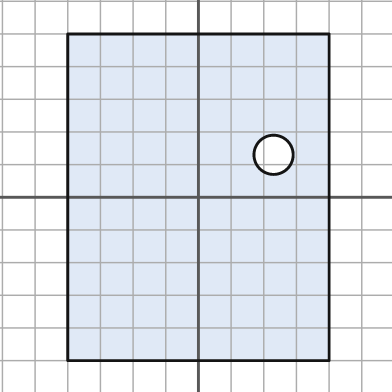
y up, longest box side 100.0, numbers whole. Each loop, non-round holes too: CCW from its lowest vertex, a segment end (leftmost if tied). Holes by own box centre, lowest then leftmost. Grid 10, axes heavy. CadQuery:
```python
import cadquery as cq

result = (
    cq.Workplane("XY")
    .moveTo(-40.0, -50.0)
    .lineTo(40.0, -50.0)
    .lineTo(40.0, 50.0)
    .lineTo(-40.0, 50.0)
    .close()
    .moveTo(23.0, 13.0)
    .circle(6.0)
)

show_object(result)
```